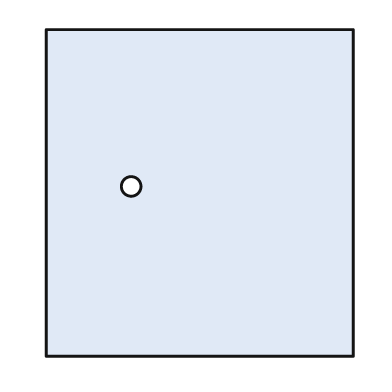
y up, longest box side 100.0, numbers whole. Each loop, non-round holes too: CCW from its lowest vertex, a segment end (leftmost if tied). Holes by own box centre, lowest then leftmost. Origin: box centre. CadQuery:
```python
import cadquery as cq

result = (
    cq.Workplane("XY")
    .moveTo(-47.0, -50.0)
    .lineTo(47.0, -50.0)
    .lineTo(47.0, 50.0)
    .lineTo(-47.0, 50.0)
    .close()
    .moveTo(-21.0, 2.0)
    .circle(3.0)
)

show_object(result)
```